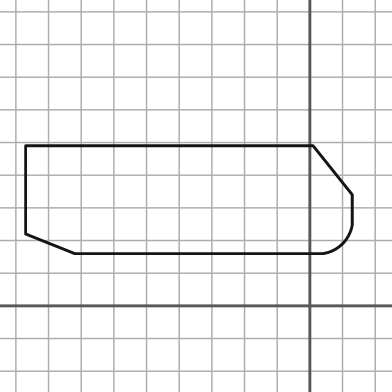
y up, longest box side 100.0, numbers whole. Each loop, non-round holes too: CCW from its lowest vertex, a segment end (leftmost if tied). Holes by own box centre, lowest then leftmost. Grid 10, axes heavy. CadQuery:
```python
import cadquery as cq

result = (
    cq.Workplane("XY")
    .moveTo(-72.0, 16.0)
    .lineTo(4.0, 16.0)
    .threePointArc((10.0, 19.0), (13.0, 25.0))
    .lineTo(13.0, 34.0)
    .lineTo(1.0, 49.0)
    .lineTo(-87.0, 49.0)
    .lineTo(-87.0, 22.0)
    .close()
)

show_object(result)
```